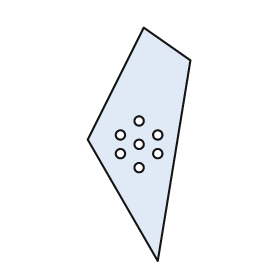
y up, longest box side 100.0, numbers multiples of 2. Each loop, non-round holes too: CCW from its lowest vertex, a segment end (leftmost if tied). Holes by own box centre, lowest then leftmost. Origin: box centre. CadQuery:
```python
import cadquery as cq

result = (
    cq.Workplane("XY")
    .moveTo(8.0, -50.0)
    .lineTo(22.0, 36.0)
    .lineTo(2.0, 50.0)
    .lineTo(-22.0, 2.0)
    .close()
    .moveTo(0.0, -10.0)
    .circle(2.0)
    .moveTo(-8.0, -4.0)
    .circle(2.0)
    .moveTo(8.0, -4.0)
    .circle(2.0)
    .moveTo(0.0, 0.0)
    .circle(2.0)
    .moveTo(-8.0, 4.0)
    .circle(2.0)
    .moveTo(8.0, 4.0)
    .circle(2.0)
    .moveTo(0.0, 10.0)
    .circle(2.0)
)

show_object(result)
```